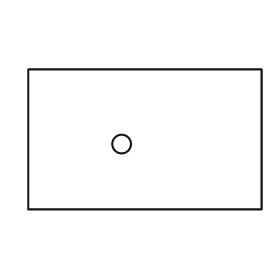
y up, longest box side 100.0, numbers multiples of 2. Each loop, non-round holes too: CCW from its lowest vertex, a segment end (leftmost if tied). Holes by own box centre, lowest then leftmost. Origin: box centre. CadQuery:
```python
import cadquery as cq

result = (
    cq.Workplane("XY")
    .moveTo(-50.0, -30.0)
    .lineTo(50.0, -30.0)
    .lineTo(50.0, 30.0)
    .lineTo(-50.0, 30.0)
    .close()
    .moveTo(-10.0, -2.0)
    .circle(4.0)
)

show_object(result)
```